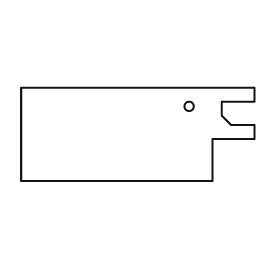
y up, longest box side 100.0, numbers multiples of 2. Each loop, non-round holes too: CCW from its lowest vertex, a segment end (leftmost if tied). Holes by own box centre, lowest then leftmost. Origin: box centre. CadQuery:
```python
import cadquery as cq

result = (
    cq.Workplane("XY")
    .moveTo(-50.0, -20.0)
    .lineTo(32.0, -20.0)
    .lineTo(32.0, -2.0)
    .lineTo(50.0, -2.0)
    .lineTo(50.0, 4.0)
    .lineTo(40.0, 4.0)
    .lineTo(36.0, 8.0)
    .lineTo(36.0, 14.0)
    .lineTo(50.0, 14.0)
    .lineTo(50.0, 20.0)
    .lineTo(-50.0, 20.0)
    .close()
    .moveTo(22.0, 12.0)
    .circle(2.0)
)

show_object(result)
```